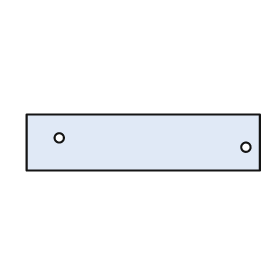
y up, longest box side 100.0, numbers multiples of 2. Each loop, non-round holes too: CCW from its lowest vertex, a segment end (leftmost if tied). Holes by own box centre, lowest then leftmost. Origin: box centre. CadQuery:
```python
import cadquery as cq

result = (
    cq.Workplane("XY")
    .moveTo(-50.0, -12.0)
    .lineTo(50.0, -12.0)
    .lineTo(50.0, 12.0)
    .lineTo(-50.0, 12.0)
    .close()
    .moveTo(44.0, -2.0)
    .circle(2.0)
    .moveTo(-36.0, 2.0)
    .circle(2.0)
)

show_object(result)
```